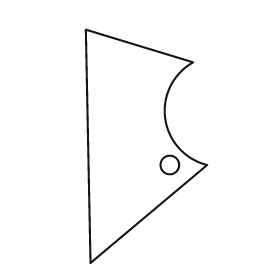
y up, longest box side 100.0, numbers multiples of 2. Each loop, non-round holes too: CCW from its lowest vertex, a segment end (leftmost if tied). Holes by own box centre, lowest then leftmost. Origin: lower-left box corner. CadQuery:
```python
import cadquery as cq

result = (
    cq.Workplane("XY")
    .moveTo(2.0, 0.0)
    .lineTo(52.0, 42.0)
    .threePointArc((34.0, 62.0), (46.0, 86.0))
    .lineTo(0.0, 100.0)
    .close()
    .moveTo(36.0, 42.0)
    .circle(4.0)
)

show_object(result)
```